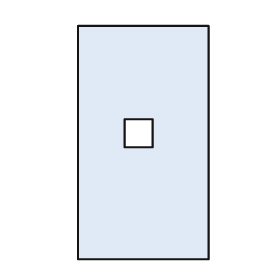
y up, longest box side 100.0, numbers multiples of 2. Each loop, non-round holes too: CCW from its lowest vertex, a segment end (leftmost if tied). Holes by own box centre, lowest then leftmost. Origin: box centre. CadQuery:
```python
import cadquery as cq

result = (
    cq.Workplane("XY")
    .moveTo(-28.0, -50.0)
    .lineTo(28.0, -50.0)
    .lineTo(28.0, 50.0)
    .lineTo(-28.0, 50.0)
    .close()
    .moveTo(-8.0, -2.0)
    .lineTo(4.0, -2.0)
    .lineTo(4.0, 10.0)
    .lineTo(-8.0, 10.0)
    .close()
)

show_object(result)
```